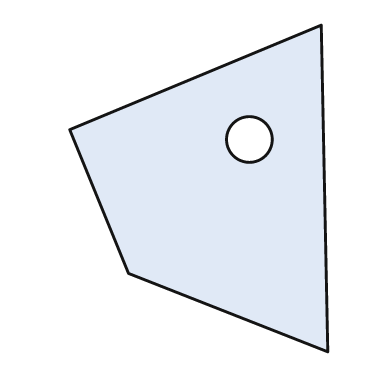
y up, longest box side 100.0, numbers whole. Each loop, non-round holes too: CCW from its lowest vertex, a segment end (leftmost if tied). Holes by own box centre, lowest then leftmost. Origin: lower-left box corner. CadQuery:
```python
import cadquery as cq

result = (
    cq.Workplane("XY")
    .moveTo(79.0, 0.0)
    .lineTo(77.0, 100.0)
    .lineTo(0.0, 68.0)
    .lineTo(18.0, 24.0)
    .close()
    .moveTo(55.0, 65.0)
    .circle(7.0)
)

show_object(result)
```